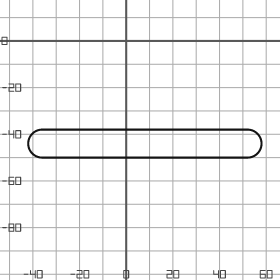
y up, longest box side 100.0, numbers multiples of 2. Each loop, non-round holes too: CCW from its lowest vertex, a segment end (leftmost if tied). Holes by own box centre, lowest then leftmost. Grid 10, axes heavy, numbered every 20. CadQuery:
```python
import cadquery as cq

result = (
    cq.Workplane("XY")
    .moveTo(-36.0, -50.0)
    .lineTo(52.0, -50.0)
    .threePointArc((58.0, -44.0), (52.0, -38.0))
    .lineTo(-36.0, -38.0)
    .threePointArc((-42.0, -44.0), (-36.0, -50.0))
    .close()
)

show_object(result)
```